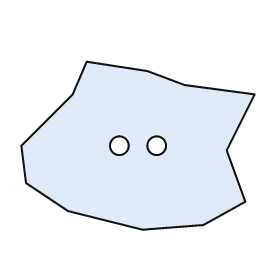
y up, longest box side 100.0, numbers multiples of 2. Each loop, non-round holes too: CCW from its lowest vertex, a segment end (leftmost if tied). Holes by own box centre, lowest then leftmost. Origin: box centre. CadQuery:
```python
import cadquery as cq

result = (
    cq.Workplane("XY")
    .moveTo(2.0, -36.0)
    .lineTo(28.0, -34.0)
    .lineTo(46.0, -24.0)
    .lineTo(38.0, -2.0)
    .lineTo(50.0, 22.0)
    .lineTo(20.0, 26.0)
    .lineTo(4.0, 32.0)
    .lineTo(-22.0, 36.0)
    .lineTo(-28.0, 22.0)
    .lineTo(-50.0, 0.0)
    .lineTo(-48.0, -16.0)
    .lineTo(-30.0, -28.0)
    .close()
    .moveTo(-8.0, 0.0)
    .circle(4.0)
    .moveTo(8.0, 0.0)
    .circle(4.0)
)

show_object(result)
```